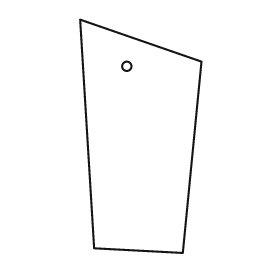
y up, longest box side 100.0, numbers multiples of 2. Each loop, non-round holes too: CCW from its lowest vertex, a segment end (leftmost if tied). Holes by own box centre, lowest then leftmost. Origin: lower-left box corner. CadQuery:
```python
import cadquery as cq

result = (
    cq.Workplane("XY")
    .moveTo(44.0, 0.0)
    .lineTo(52.0, 82.0)
    .lineTo(0.0, 100.0)
    .lineTo(6.0, 2.0)
    .close()
    .moveTo(20.0, 80.0)
    .circle(2.0)
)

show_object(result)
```